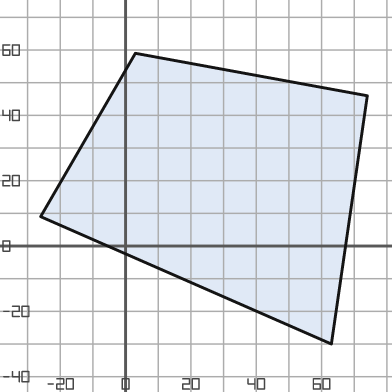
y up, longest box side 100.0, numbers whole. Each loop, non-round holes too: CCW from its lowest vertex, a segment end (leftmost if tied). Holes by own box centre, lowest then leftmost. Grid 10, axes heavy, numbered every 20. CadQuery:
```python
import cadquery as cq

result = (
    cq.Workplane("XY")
    .moveTo(63.0, -30.0)
    .lineTo(74.0, 46.0)
    .lineTo(3.0, 59.0)
    .lineTo(-26.0, 9.0)
    .close()
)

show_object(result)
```